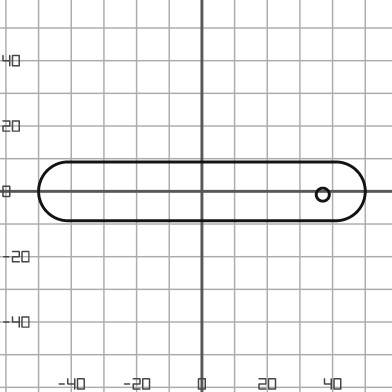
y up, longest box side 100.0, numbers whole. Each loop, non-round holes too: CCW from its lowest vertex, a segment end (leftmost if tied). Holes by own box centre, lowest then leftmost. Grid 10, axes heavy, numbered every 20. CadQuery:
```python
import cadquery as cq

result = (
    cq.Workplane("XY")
    .moveTo(-41.0, -9.0)
    .lineTo(41.0, -9.0)
    .threePointArc((50.0, 0.0), (41.0, 9.0))
    .lineTo(-41.0, 9.0)
    .threePointArc((-50.0, 0.0), (-41.0, -9.0))
    .close()
    .moveTo(37.0, -1.0)
    .circle(2.0)
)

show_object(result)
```